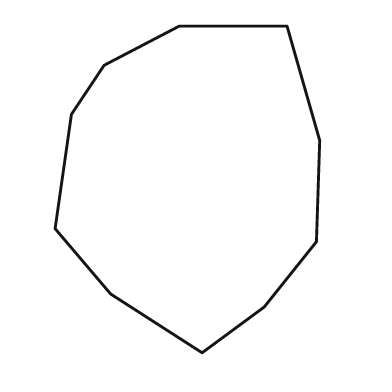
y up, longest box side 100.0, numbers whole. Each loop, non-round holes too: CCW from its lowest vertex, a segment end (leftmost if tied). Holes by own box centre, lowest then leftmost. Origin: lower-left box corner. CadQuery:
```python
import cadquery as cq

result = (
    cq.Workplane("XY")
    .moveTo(45.0, 0.0)
    .lineTo(64.0, 14.0)
    .lineTo(80.0, 34.0)
    .lineTo(81.0, 65.0)
    .lineTo(71.0, 100.0)
    .lineTo(38.0, 100.0)
    .lineTo(15.0, 88.0)
    .lineTo(5.0, 73.0)
    .lineTo(0.0, 38.0)
    .lineTo(17.0, 18.0)
    .close()
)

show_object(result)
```